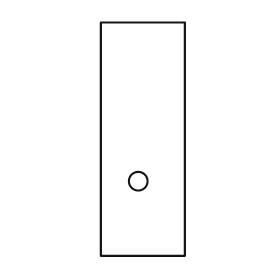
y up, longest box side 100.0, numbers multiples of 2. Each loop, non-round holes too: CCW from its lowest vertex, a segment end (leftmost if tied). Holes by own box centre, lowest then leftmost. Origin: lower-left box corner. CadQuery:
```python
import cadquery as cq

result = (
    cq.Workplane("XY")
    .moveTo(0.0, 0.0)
    .lineTo(36.0, 0.0)
    .lineTo(36.0, 100.0)
    .lineTo(0.0, 100.0)
    .close()
    .moveTo(16.0, 32.0)
    .circle(4.0)
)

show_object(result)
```